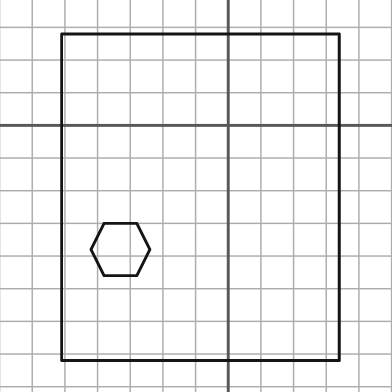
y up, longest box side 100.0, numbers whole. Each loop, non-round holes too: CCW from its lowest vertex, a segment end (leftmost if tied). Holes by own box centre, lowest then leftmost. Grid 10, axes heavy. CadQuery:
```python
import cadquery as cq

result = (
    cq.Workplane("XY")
    .moveTo(-51.0, -72.0)
    .lineTo(34.0, -72.0)
    .lineTo(34.0, 28.0)
    .lineTo(-51.0, 28.0)
    .close()
    .moveTo(-38.0, -46.0)
    .lineTo(-28.0, -46.0)
    .lineTo(-24.0, -38.0)
    .lineTo(-28.0, -30.0)
    .lineTo(-38.0, -30.0)
    .lineTo(-42.0, -38.0)
    .close()
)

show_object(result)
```